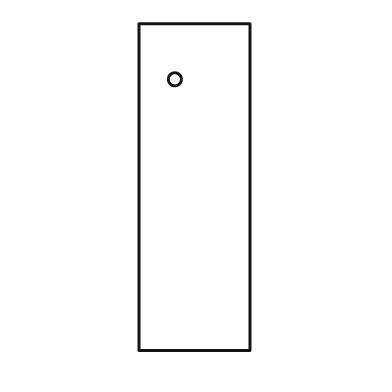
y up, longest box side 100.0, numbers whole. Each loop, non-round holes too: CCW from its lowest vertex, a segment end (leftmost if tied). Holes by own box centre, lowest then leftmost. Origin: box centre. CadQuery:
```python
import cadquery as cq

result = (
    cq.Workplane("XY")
    .moveTo(-17.0, -50.0)
    .lineTo(17.0, -50.0)
    .lineTo(17.0, 50.0)
    .lineTo(-17.0, 50.0)
    .close()
    .moveTo(-6.0, 33.0)
    .circle(2.0)
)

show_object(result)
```